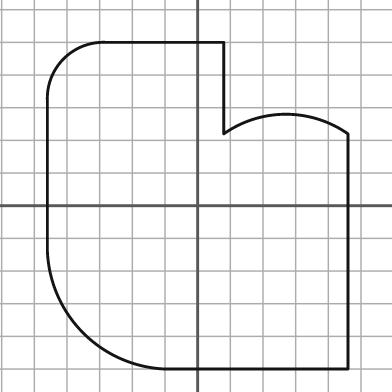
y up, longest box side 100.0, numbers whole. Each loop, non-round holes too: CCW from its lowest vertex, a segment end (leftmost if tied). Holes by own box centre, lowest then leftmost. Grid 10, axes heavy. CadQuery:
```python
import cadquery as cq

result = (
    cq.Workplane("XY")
    .moveTo(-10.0, -50.0)
    .lineTo(46.0, -50.0)
    .lineTo(46.0, 22.0)
    .threePointArc((27.0, 28.0), (8.0, 22.0))
    .lineTo(8.0, 50.0)
    .lineTo(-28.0, 50.0)
    .threePointArc((-41.0, 45.0), (-46.0, 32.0))
    .lineTo(-46.0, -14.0)
    .threePointArc((-35.0, -39.0), (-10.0, -50.0))
    .close()
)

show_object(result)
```